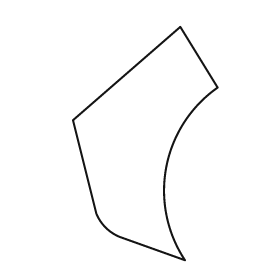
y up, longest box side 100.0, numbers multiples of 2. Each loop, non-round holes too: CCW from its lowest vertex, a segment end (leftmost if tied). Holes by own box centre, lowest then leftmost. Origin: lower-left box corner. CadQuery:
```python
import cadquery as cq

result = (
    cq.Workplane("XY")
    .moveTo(48.0, 0.0)
    .threePointArc((40.0, 40.0), (62.0, 74.0))
    .lineTo(46.0, 100.0)
    .lineTo(0.0, 60.0)
    .lineTo(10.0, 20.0)
    .threePointArc((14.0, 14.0), (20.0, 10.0))
    .close()
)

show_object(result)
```